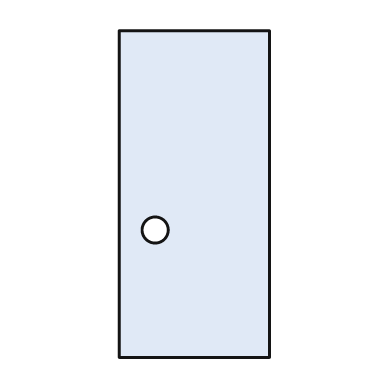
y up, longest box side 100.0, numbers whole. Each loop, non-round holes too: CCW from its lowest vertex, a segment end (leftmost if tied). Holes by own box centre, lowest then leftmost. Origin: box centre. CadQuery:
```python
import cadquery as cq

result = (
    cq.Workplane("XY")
    .moveTo(-23.0, -50.0)
    .lineTo(23.0, -50.0)
    .lineTo(23.0, 50.0)
    .lineTo(-23.0, 50.0)
    .close()
    .moveTo(-12.0, -11.0)
    .circle(4.0)
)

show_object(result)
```